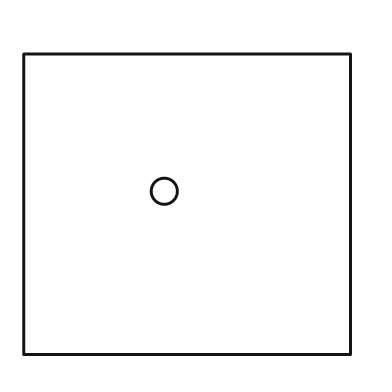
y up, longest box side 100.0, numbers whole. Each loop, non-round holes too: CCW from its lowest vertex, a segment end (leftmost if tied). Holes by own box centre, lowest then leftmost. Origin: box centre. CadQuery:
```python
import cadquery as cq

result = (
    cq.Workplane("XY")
    .moveTo(-50.0, -46.0)
    .lineTo(50.0, -46.0)
    .lineTo(50.0, 46.0)
    .lineTo(-50.0, 46.0)
    .close()
    .moveTo(-7.0, 4.0)
    .circle(4.0)
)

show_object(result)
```